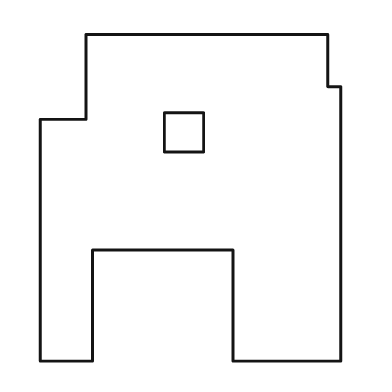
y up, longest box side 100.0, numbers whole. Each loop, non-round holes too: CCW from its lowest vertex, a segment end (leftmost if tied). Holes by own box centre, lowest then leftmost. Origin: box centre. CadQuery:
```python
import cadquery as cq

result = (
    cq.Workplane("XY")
    .moveTo(-46.0, -50.0)
    .lineTo(-30.0, -50.0)
    .lineTo(-30.0, -16.0)
    .lineTo(13.0, -16.0)
    .lineTo(13.0, -50.0)
    .lineTo(46.0, -50.0)
    .lineTo(46.0, 34.0)
    .lineTo(42.0, 34.0)
    .lineTo(42.0, 50.0)
    .lineTo(-32.0, 50.0)
    .lineTo(-32.0, 24.0)
    .lineTo(-46.0, 24.0)
    .close()
    .moveTo(-8.0, 14.0)
    .lineTo(4.0, 14.0)
    .lineTo(4.0, 26.0)
    .lineTo(-8.0, 26.0)
    .close()
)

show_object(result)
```